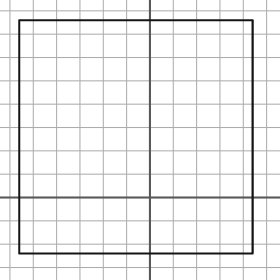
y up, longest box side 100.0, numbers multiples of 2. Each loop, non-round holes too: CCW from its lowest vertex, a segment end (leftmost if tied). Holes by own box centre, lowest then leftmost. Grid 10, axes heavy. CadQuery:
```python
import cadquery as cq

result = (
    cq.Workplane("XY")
    .moveTo(-56.0, -24.0)
    .lineTo(44.0, -24.0)
    .lineTo(44.0, 76.0)
    .lineTo(-56.0, 76.0)
    .close()
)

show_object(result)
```